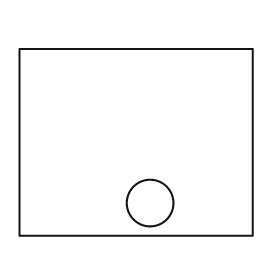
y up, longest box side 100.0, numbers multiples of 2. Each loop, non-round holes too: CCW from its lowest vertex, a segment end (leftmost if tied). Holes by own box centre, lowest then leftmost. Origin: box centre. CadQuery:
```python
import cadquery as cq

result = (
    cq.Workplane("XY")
    .moveTo(-50.0, -40.0)
    .lineTo(50.0, -40.0)
    .lineTo(50.0, 40.0)
    .lineTo(-50.0, 40.0)
    .close()
    .moveTo(6.0, -26.0)
    .circle(10.0)
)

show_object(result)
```